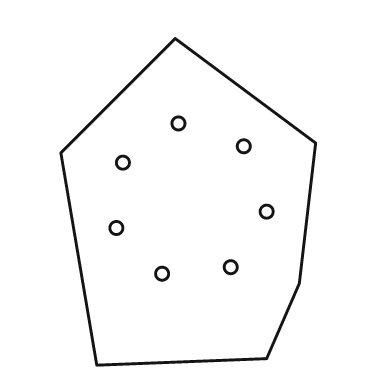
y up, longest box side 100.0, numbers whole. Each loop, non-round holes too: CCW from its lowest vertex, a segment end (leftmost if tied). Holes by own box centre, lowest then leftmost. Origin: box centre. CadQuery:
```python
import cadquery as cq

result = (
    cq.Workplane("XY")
    .moveTo(-28.0, -50.0)
    .lineTo(24.0, -48.0)
    .lineTo(34.0, -25.0)
    .lineTo(39.0, 18.0)
    .lineTo(-4.0, 50.0)
    .lineTo(-39.0, 15.0)
    .close()
    .moveTo(-8.0, -22.0)
    .circle(2.0)
    .moveTo(13.0, -20.0)
    .circle(2.0)
    .moveTo(-22.0, -8.0)
    .circle(2.0)
    .moveTo(24.0, -3.0)
    .circle(2.0)
    .moveTo(-20.0, 12.0)
    .circle(2.0)
    .moveTo(17.0, 17.0)
    .circle(2.0)
    .moveTo(-3.0, 24.0)
    .circle(2.0)
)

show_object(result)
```